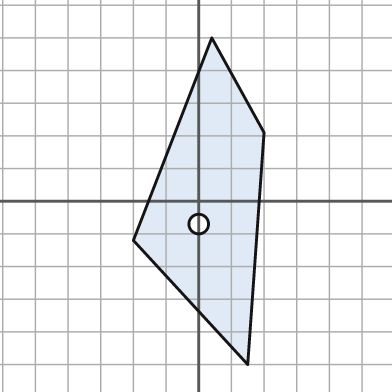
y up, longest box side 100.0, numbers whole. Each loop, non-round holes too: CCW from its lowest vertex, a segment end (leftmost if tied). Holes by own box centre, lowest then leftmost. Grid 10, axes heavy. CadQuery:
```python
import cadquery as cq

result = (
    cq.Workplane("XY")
    .moveTo(15.0, -50.0)
    .lineTo(20.0, 21.0)
    .lineTo(4.0, 50.0)
    .lineTo(-20.0, -12.0)
    .close()
    .moveTo(0.0, -7.0)
    .circle(3.0)
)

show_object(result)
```